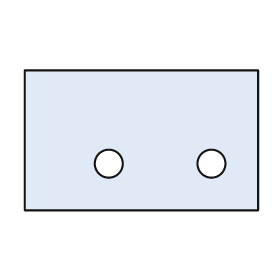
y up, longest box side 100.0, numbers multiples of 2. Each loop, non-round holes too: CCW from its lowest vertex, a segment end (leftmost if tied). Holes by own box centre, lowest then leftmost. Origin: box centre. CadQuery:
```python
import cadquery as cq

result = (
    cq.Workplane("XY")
    .moveTo(-50.0, -30.0)
    .lineTo(50.0, -30.0)
    .lineTo(50.0, 30.0)
    .lineTo(-50.0, 30.0)
    .close()
    .moveTo(-14.0, -10.0)
    .circle(6.0)
    .moveTo(30.0, -10.0)
    .circle(6.0)
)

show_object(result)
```